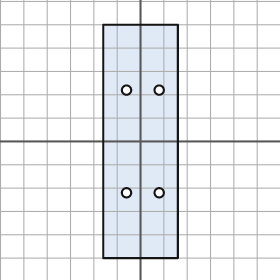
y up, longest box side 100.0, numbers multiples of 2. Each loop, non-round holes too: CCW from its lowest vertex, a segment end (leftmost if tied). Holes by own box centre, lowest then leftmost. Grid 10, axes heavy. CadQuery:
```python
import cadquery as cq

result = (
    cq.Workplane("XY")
    .moveTo(-16.0, -50.0)
    .lineTo(16.0, -50.0)
    .lineTo(16.0, 50.0)
    .lineTo(-16.0, 50.0)
    .close()
    .moveTo(-6.0, -22.0)
    .circle(2.0)
    .moveTo(8.0, -22.0)
    .circle(2.0)
    .moveTo(-6.0, 22.0)
    .circle(2.0)
    .moveTo(8.0, 22.0)
    .circle(2.0)
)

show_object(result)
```